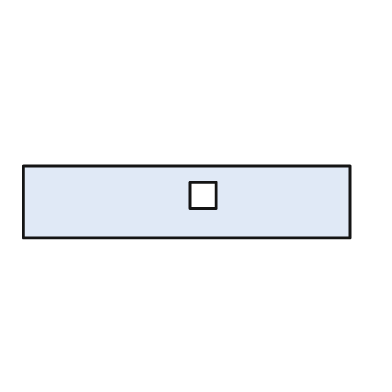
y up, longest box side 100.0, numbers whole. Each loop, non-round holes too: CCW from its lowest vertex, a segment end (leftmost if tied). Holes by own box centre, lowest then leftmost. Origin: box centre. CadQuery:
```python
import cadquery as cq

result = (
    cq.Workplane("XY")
    .moveTo(-50.0, -11.0)
    .lineTo(50.0, -11.0)
    .lineTo(50.0, 11.0)
    .lineTo(-50.0, 11.0)
    .close()
    .moveTo(1.0, -2.0)
    .lineTo(9.0, -2.0)
    .lineTo(9.0, 6.0)
    .lineTo(1.0, 6.0)
    .close()
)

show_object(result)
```